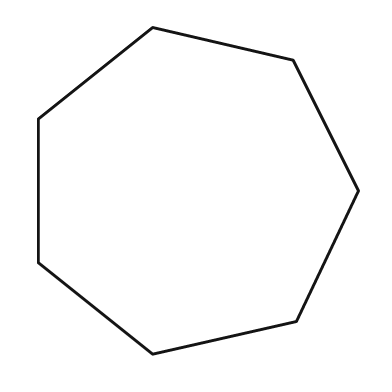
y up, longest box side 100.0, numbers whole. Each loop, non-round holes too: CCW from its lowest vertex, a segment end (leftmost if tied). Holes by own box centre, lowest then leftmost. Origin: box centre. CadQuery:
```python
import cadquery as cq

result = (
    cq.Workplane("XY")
    .moveTo(-14.0, -50.0)
    .lineTo(30.0, -40.0)
    .lineTo(49.0, 0.0)
    .lineTo(29.0, 40.0)
    .lineTo(-14.0, 50.0)
    .lineTo(-49.0, 22.0)
    .lineTo(-49.0, -22.0)
    .close()
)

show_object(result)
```